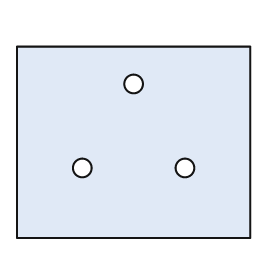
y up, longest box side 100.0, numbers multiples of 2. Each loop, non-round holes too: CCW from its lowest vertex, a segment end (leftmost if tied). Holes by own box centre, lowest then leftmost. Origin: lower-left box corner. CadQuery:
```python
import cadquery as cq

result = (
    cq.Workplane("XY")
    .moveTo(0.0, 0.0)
    .lineTo(100.0, 0.0)
    .lineTo(100.0, 82.0)
    .lineTo(0.0, 82.0)
    .close()
    .moveTo(28.0, 30.0)
    .circle(4.0)
    .moveTo(72.0, 30.0)
    .circle(4.0)
    .moveTo(50.0, 66.0)
    .circle(4.0)
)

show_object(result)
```